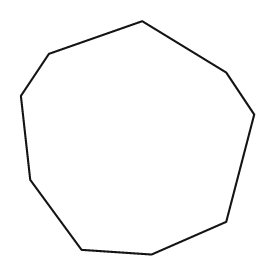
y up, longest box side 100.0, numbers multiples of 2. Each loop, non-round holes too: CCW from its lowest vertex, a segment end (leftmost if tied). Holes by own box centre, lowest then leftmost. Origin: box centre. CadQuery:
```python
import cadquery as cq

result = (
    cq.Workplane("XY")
    .moveTo(6.0, -50.0)
    .lineTo(38.0, -36.0)
    .lineTo(50.0, 10.0)
    .lineTo(38.0, 28.0)
    .lineTo(2.0, 50.0)
    .lineTo(-38.0, 36.0)
    .lineTo(-50.0, 18.0)
    .lineTo(-46.0, -18.0)
    .lineTo(-24.0, -48.0)
    .close()
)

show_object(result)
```